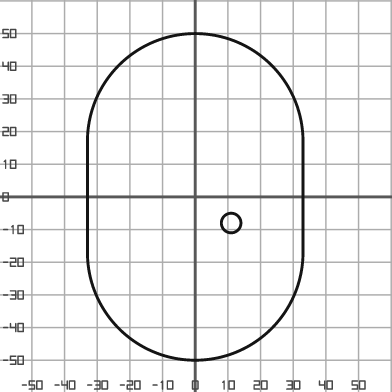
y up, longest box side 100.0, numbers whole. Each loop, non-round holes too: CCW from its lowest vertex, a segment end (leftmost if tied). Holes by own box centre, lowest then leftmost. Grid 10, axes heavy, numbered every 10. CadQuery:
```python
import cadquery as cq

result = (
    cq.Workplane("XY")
    .moveTo(-33.0, -17.0)
    .threePointArc((0.0, -50.0), (33.0, -17.0))
    .lineTo(33.0, 17.0)
    .threePointArc((0.0, 50.0), (-33.0, 17.0))
    .close()
    .moveTo(11.0, -8.0)
    .circle(3.0)
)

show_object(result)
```